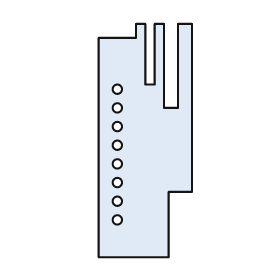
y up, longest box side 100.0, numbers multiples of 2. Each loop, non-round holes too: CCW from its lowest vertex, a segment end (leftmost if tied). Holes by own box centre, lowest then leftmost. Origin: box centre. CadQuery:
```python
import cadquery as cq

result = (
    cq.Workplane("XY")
    .moveTo(-20.0, -50.0)
    .lineTo(10.0, -50.0)
    .lineTo(10.0, -22.0)
    .lineTo(20.0, -22.0)
    .lineTo(20.0, 50.0)
    .lineTo(14.0, 50.0)
    .lineTo(14.0, 14.0)
    .lineTo(8.0, 14.0)
    .lineTo(8.0, 50.0)
    .lineTo(4.0, 50.0)
    .lineTo(4.0, 24.0)
    .lineTo(0.0, 24.0)
    .lineTo(0.0, 50.0)
    .lineTo(-4.0, 50.0)
    .lineTo(-4.0, 44.0)
    .lineTo(-20.0, 44.0)
    .close()
    .moveTo(-12.0, -34.0)
    .circle(2.0)
    .moveTo(-12.0, -26.0)
    .circle(2.0)
    .moveTo(-12.0, -18.0)
    .circle(2.0)
    .moveTo(-12.0, -10.0)
    .circle(2.0)
    .moveTo(-12.0, -2.0)
    .circle(2.0)
    .moveTo(-12.0, 6.0)
    .circle(2.0)
    .moveTo(-12.0, 14.0)
    .circle(2.0)
    .moveTo(-12.0, 22.0)
    .circle(2.0)
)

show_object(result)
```